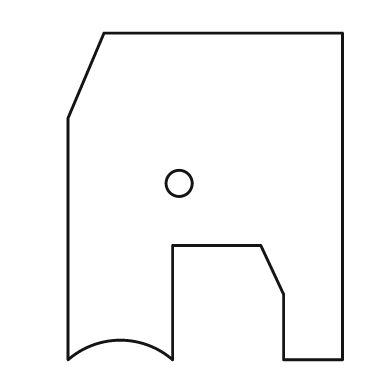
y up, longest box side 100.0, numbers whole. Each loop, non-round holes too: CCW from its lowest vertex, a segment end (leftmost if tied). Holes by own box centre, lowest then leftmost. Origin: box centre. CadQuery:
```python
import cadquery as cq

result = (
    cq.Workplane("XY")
    .moveTo(-42.0, -50.0)
    .threePointArc((-26.0, -44.0), (-10.0, -50.0))
    .lineTo(-10.0, -15.0)
    .lineTo(17.0, -15.0)
    .lineTo(24.0, -30.0)
    .lineTo(24.0, -50.0)
    .lineTo(42.0, -50.0)
    .lineTo(42.0, 50.0)
    .lineTo(-31.0, 50.0)
    .lineTo(-42.0, 24.0)
    .close()
    .moveTo(-8.0, 4.0)
    .circle(4.0)
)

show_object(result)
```